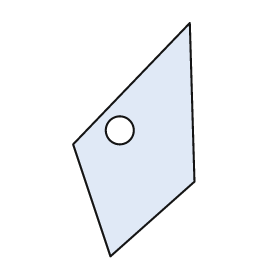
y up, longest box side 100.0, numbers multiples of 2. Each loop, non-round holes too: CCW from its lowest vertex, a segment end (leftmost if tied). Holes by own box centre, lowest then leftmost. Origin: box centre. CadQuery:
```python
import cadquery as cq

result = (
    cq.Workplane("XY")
    .moveTo(-10.0, -50.0)
    .lineTo(26.0, -18.0)
    .lineTo(24.0, 50.0)
    .lineTo(-26.0, -2.0)
    .close()
    .moveTo(-6.0, 4.0)
    .circle(6.0)
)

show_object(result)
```